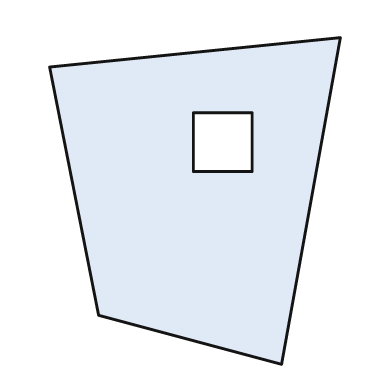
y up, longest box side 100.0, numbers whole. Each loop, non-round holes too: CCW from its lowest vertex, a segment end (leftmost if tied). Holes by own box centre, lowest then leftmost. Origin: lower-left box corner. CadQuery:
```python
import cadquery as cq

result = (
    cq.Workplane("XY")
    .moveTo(71.0, 0.0)
    .lineTo(89.0, 100.0)
    .lineTo(0.0, 91.0)
    .lineTo(15.0, 15.0)
    .close()
    .moveTo(44.0, 59.0)
    .lineTo(62.0, 59.0)
    .lineTo(62.0, 77.0)
    .lineTo(44.0, 77.0)
    .close()
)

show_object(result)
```